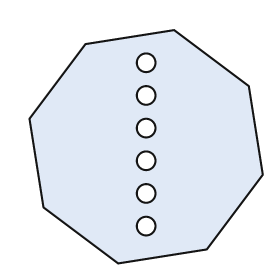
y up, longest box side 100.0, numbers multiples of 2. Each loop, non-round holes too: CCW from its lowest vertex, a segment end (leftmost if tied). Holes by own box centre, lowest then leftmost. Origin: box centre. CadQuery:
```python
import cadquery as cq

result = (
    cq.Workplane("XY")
    .moveTo(-12.0, -50.0)
    .lineTo(26.0, -44.0)
    .lineTo(50.0, -12.0)
    .lineTo(44.0, 26.0)
    .lineTo(12.0, 50.0)
    .lineTo(-26.0, 44.0)
    .lineTo(-50.0, 12.0)
    .lineTo(-44.0, -26.0)
    .close()
    .moveTo(0.0, -34.0)
    .circle(4.0)
    .moveTo(0.0, -20.0)
    .circle(4.0)
    .moveTo(0.0, -6.0)
    .circle(4.0)
    .moveTo(0.0, 8.0)
    .circle(4.0)
    .moveTo(0.0, 22.0)
    .circle(4.0)
    .moveTo(0.0, 36.0)
    .circle(4.0)
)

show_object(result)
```